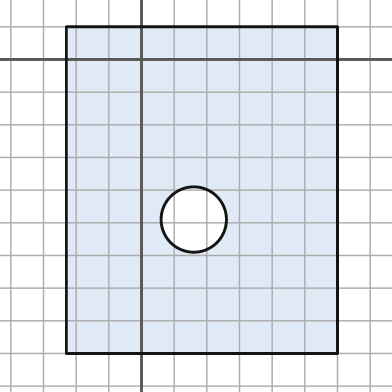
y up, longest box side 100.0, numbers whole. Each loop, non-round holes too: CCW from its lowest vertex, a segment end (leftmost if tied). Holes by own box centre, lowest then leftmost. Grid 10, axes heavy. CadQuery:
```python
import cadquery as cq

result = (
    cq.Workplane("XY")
    .moveTo(-23.0, -90.0)
    .lineTo(60.0, -90.0)
    .lineTo(60.0, 10.0)
    .lineTo(-23.0, 10.0)
    .close()
    .moveTo(16.0, -49.0)
    .circle(10.0)
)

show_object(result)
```